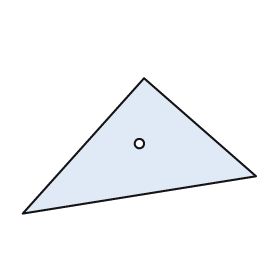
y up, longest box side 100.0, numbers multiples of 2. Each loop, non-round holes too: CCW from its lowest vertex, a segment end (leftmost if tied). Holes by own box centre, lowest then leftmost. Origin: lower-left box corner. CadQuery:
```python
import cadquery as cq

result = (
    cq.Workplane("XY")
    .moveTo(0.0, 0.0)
    .lineTo(100.0, 16.0)
    .lineTo(52.0, 58.0)
    .close()
    .moveTo(50.0, 30.0)
    .circle(2.0)
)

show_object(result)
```